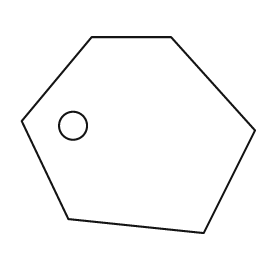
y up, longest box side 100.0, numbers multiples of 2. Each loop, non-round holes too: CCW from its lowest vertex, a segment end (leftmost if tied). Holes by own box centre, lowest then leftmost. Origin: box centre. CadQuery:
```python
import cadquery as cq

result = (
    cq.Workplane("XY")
    .moveTo(28.0, -42.0)
    .lineTo(50.0, 2.0)
    .lineTo(14.0, 42.0)
    .lineTo(-20.0, 42.0)
    .lineTo(-50.0, 6.0)
    .lineTo(-30.0, -36.0)
    .close()
    .moveTo(-28.0, 4.0)
    .circle(6.0)
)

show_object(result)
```